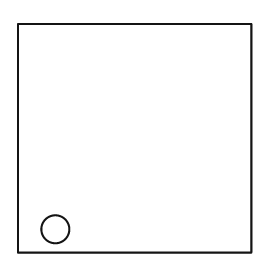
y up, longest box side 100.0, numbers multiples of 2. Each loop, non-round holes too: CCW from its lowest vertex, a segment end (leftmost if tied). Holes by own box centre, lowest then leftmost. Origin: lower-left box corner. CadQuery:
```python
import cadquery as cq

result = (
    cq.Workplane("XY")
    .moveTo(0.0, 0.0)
    .lineTo(100.0, 0.0)
    .lineTo(100.0, 98.0)
    .lineTo(0.0, 98.0)
    .close()
    .moveTo(16.0, 10.0)
    .circle(6.0)
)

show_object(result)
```